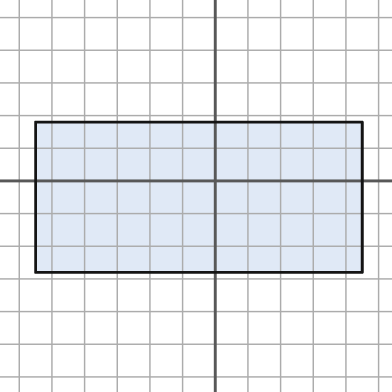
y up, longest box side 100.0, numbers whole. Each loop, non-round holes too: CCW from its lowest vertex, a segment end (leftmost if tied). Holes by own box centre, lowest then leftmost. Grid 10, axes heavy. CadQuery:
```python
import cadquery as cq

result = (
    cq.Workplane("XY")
    .moveTo(-55.0, -28.0)
    .lineTo(45.0, -28.0)
    .lineTo(45.0, 18.0)
    .lineTo(-55.0, 18.0)
    .close()
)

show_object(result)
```